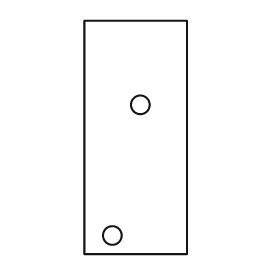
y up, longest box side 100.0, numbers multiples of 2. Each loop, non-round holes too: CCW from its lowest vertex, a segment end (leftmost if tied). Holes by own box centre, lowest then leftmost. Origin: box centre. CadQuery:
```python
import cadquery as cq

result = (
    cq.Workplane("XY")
    .moveTo(-22.0, -50.0)
    .lineTo(22.0, -50.0)
    .lineTo(22.0, 50.0)
    .lineTo(-22.0, 50.0)
    .close()
    .moveTo(-10.0, -42.0)
    .circle(4.0)
    .moveTo(2.0, 14.0)
    .circle(4.0)
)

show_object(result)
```